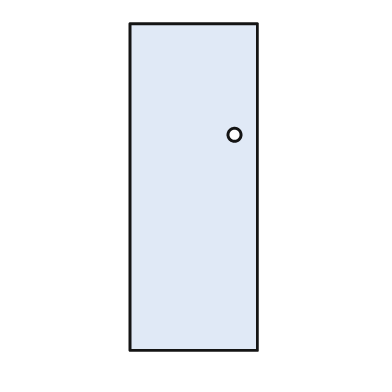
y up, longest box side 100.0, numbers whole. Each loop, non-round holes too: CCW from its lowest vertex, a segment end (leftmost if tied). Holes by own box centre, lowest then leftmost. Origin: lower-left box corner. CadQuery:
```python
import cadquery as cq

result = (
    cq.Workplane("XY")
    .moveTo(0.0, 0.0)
    .lineTo(39.0, 0.0)
    .lineTo(39.0, 100.0)
    .lineTo(0.0, 100.0)
    .close()
    .moveTo(32.0, 66.0)
    .circle(2.0)
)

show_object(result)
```